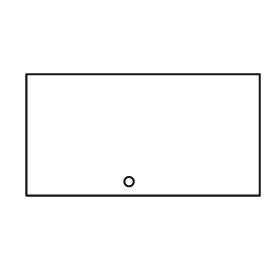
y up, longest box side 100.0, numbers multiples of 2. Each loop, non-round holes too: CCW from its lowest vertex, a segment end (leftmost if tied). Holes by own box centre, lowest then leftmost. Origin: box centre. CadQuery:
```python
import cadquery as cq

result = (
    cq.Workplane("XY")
    .moveTo(-50.0, -26.0)
    .lineTo(50.0, -26.0)
    .lineTo(50.0, 26.0)
    .lineTo(-50.0, 26.0)
    .close()
    .moveTo(-6.0, -20.0)
    .circle(2.0)
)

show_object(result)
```